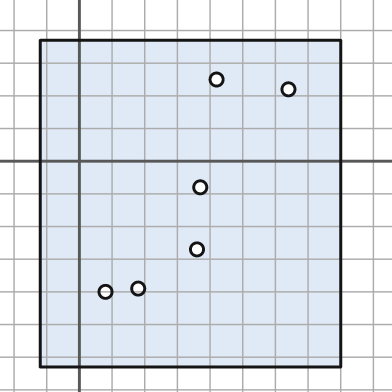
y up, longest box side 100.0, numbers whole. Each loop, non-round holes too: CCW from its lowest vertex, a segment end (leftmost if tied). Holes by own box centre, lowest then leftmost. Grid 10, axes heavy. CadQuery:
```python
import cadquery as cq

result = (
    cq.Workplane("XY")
    .moveTo(-12.0, -63.0)
    .lineTo(80.0, -63.0)
    .lineTo(80.0, 37.0)
    .lineTo(-12.0, 37.0)
    .close()
    .moveTo(8.0, -40.0)
    .circle(2.0)
    .moveTo(18.0, -39.0)
    .circle(2.0)
    .moveTo(36.0, -27.0)
    .circle(2.0)
    .moveTo(37.0, -8.0)
    .circle(2.0)
    .moveTo(64.0, 22.0)
    .circle(2.0)
    .moveTo(42.0, 25.0)
    .circle(2.0)
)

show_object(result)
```